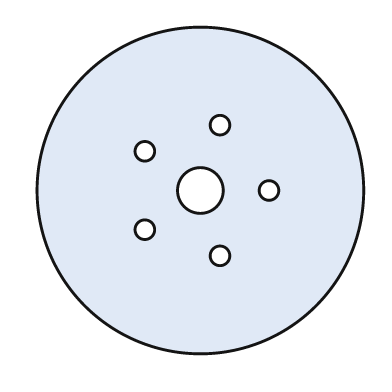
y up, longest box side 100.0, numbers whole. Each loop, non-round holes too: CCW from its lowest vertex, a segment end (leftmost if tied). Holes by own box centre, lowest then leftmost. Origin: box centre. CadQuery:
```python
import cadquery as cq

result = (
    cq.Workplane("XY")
    .moveTo(0.0, 0.0)
    .circle(50.0)
    .moveTo(6.0, -20.0)
    .circle(3.0)
    .moveTo(-17.0, -12.0)
    .circle(3.0)
    .moveTo(0.0, 0.0)
    .circle(7.0)
    .moveTo(21.0, 0.0)
    .circle(3.0)
    .moveTo(-17.0, 12.0)
    .circle(3.0)
    .moveTo(6.0, 20.0)
    .circle(3.0)
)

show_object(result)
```